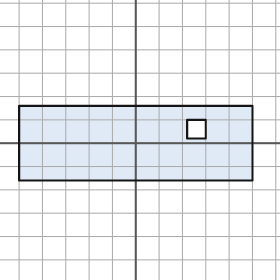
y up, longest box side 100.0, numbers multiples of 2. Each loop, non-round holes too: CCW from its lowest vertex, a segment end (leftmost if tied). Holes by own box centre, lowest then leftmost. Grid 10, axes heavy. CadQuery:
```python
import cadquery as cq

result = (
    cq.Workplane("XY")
    .moveTo(-50.0, -16.0)
    .lineTo(50.0, -16.0)
    .lineTo(50.0, 16.0)
    .lineTo(-50.0, 16.0)
    .close()
    .moveTo(22.0, 2.0)
    .lineTo(30.0, 2.0)
    .lineTo(30.0, 10.0)
    .lineTo(22.0, 10.0)
    .close()
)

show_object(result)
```